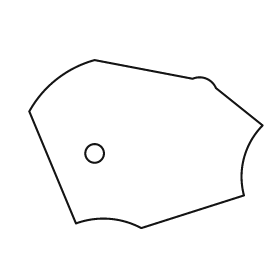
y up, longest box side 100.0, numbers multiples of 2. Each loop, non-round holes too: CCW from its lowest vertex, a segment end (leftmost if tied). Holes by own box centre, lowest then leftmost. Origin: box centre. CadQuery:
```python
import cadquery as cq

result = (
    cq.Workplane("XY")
    .moveTo(-2.0, -36.0)
    .lineTo(42.0, -22.0)
    .threePointArc((42.0, -6.0), (50.0, 8.0))
    .lineTo(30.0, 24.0)
    .threePointArc((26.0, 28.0), (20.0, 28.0))
    .lineTo(-22.0, 36.0)
    .threePointArc((-38.0, 28.0), (-50.0, 14.0))
    .lineTo(-30.0, -34.0)
    .threePointArc((-16.0, -32.0), (-2.0, -36.0))
    .close()
    .moveTo(-22.0, -4.0)
    .circle(4.0)
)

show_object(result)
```